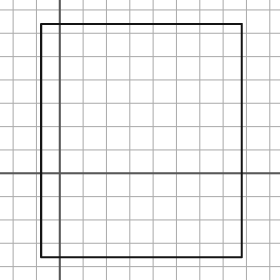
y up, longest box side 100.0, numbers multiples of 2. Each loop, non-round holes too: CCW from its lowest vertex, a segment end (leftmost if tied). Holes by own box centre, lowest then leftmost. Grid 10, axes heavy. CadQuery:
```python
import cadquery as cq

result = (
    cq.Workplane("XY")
    .moveTo(-8.0, -36.0)
    .lineTo(78.0, -36.0)
    .lineTo(78.0, 64.0)
    .lineTo(-8.0, 64.0)
    .close()
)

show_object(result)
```